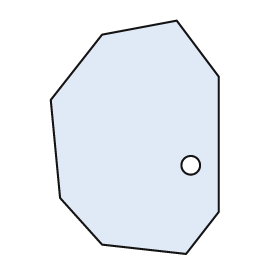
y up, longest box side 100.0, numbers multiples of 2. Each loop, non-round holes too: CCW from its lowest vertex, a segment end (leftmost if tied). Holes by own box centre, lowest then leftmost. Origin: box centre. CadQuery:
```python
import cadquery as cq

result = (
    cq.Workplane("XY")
    .moveTo(22.0, -50.0)
    .lineTo(36.0, -32.0)
    .lineTo(36.0, 26.0)
    .lineTo(18.0, 50.0)
    .lineTo(-14.0, 44.0)
    .lineTo(-36.0, 16.0)
    .lineTo(-32.0, -26.0)
    .lineTo(-14.0, -46.0)
    .close()
    .moveTo(24.0, -12.0)
    .circle(4.0)
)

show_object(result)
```